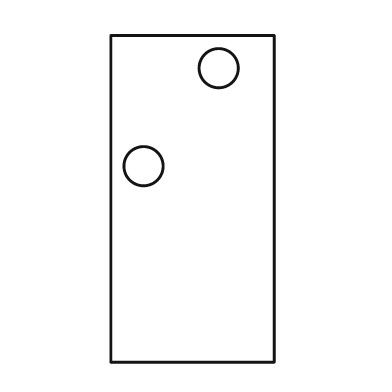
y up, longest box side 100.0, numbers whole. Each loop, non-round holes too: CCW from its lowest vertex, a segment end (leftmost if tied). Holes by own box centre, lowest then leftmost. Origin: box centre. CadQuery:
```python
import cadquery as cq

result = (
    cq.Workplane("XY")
    .moveTo(-25.0, -50.0)
    .lineTo(25.0, -50.0)
    .lineTo(25.0, 50.0)
    .lineTo(-25.0, 50.0)
    .close()
    .moveTo(-15.0, 10.0)
    .circle(6.0)
    .moveTo(8.0, 40.0)
    .circle(6.0)
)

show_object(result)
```